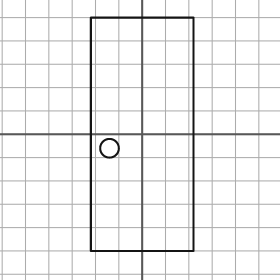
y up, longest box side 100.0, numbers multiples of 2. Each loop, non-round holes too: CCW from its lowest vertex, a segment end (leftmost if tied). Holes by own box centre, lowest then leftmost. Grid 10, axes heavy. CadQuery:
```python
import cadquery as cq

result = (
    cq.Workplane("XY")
    .moveTo(-22.0, -50.0)
    .lineTo(22.0, -50.0)
    .lineTo(22.0, 50.0)
    .lineTo(-22.0, 50.0)
    .close()
    .moveTo(-14.0, -6.0)
    .circle(4.0)
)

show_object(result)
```